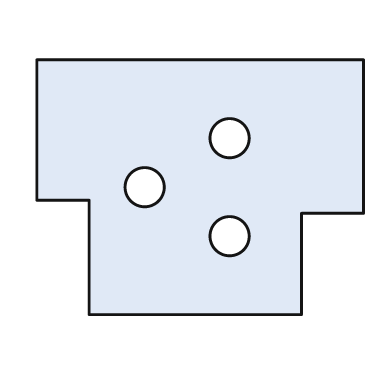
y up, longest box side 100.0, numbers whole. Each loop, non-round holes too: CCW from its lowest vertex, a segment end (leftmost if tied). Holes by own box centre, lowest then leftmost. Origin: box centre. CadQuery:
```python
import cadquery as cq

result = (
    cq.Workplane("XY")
    .moveTo(-34.0, -39.0)
    .lineTo(31.0, -39.0)
    .lineTo(31.0, -8.0)
    .lineTo(50.0, -8.0)
    .lineTo(50.0, 39.0)
    .lineTo(-50.0, 39.0)
    .lineTo(-50.0, -4.0)
    .lineTo(-34.0, -4.0)
    .close()
    .moveTo(9.0, -15.0)
    .circle(6.0)
    .moveTo(-17.0, 0.0)
    .circle(6.0)
    .moveTo(9.0, 15.0)
    .circle(6.0)
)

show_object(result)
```